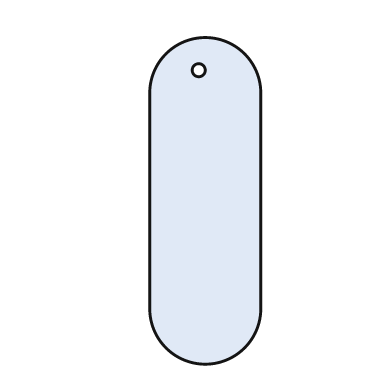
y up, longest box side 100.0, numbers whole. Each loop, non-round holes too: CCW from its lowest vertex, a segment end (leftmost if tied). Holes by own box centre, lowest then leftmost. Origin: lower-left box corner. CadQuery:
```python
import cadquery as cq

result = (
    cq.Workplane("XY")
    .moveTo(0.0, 17.0)
    .threePointArc((17.0, 0.0), (34.0, 17.0))
    .lineTo(34.0, 83.0)
    .threePointArc((17.0, 100.0), (0.0, 83.0))
    .close()
    .moveTo(15.0, 90.0)
    .circle(2.0)
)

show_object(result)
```